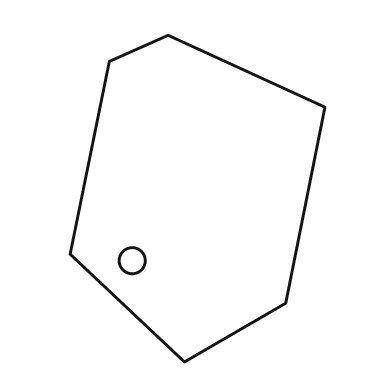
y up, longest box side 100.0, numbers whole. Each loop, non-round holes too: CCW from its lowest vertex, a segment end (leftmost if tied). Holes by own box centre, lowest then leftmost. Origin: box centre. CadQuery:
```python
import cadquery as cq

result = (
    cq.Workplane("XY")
    .moveTo(-4.0, -50.0)
    .lineTo(27.0, -32.0)
    .lineTo(39.0, 28.0)
    .lineTo(-9.0, 50.0)
    .lineTo(-27.0, 42.0)
    .lineTo(-39.0, -17.0)
    .close()
    .moveTo(-20.0, -19.0)
    .circle(4.0)
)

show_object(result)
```